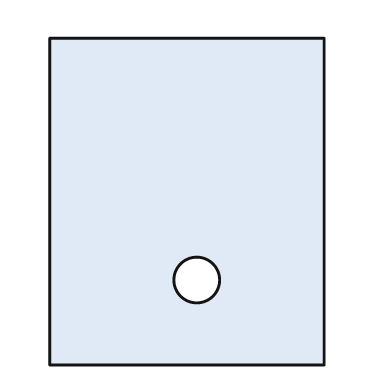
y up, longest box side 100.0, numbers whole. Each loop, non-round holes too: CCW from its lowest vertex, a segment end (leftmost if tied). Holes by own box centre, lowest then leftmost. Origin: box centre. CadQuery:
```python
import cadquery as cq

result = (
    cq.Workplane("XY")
    .moveTo(-42.0, -50.0)
    .lineTo(42.0, -50.0)
    .lineTo(42.0, 50.0)
    .lineTo(-42.0, 50.0)
    .close()
    .moveTo(3.0, -24.0)
    .circle(7.0)
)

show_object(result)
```